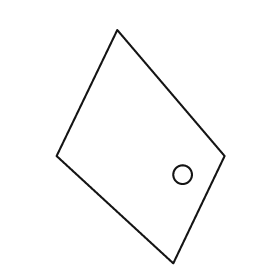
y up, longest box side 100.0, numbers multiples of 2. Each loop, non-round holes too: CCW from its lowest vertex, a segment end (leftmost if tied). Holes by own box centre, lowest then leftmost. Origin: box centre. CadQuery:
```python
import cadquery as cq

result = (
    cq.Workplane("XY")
    .moveTo(14.0, -50.0)
    .lineTo(36.0, -4.0)
    .lineTo(-10.0, 50.0)
    .lineTo(-36.0, -4.0)
    .close()
    .moveTo(18.0, -12.0)
    .circle(4.0)
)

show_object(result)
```